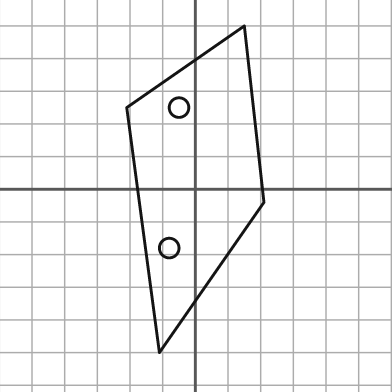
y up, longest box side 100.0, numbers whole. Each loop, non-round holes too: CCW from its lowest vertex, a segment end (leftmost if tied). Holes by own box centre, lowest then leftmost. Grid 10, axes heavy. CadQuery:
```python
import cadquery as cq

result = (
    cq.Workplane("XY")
    .moveTo(-11.0, -50.0)
    .lineTo(21.0, -4.0)
    .lineTo(15.0, 50.0)
    .lineTo(-21.0, 25.0)
    .close()
    .moveTo(-8.0, -18.0)
    .circle(3.0)
    .moveTo(-5.0, 25.0)
    .circle(3.0)
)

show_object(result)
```